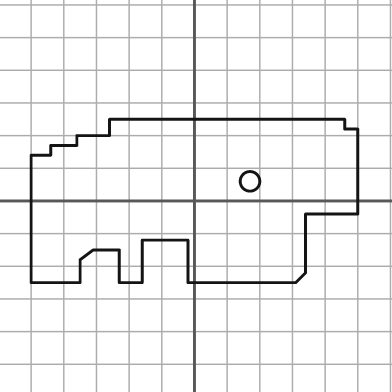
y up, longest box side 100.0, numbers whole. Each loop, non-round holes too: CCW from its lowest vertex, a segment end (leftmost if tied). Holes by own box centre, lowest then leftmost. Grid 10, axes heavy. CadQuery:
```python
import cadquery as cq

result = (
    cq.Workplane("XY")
    .moveTo(-50.0, -25.0)
    .lineTo(-35.0, -25.0)
    .lineTo(-35.0, -18.0)
    .lineTo(-31.0, -15.0)
    .lineTo(-23.0, -15.0)
    .lineTo(-23.0, -25.0)
    .lineTo(-16.0, -25.0)
    .lineTo(-16.0, -12.0)
    .lineTo(-2.0, -12.0)
    .lineTo(-2.0, -25.0)
    .lineTo(31.0, -25.0)
    .lineTo(34.0, -22.0)
    .lineTo(34.0, -4.0)
    .lineTo(50.0, -4.0)
    .lineTo(50.0, 22.0)
    .lineTo(46.0, 22.0)
    .lineTo(46.0, 25.0)
    .lineTo(-26.0, 25.0)
    .lineTo(-26.0, 20.0)
    .lineTo(-36.0, 20.0)
    .lineTo(-36.0, 17.0)
    .lineTo(-44.0, 17.0)
    .lineTo(-44.0, 14.0)
    .lineTo(-50.0, 14.0)
    .close()
    .moveTo(17.0, 6.0)
    .circle(3.0)
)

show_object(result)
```